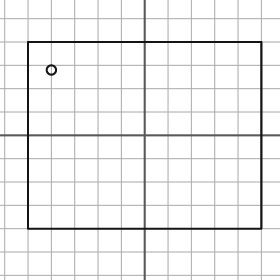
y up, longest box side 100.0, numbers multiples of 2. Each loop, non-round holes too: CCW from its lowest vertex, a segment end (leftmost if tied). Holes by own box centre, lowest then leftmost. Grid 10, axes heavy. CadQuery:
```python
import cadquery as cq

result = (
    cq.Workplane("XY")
    .moveTo(-50.0, -40.0)
    .lineTo(50.0, -40.0)
    .lineTo(50.0, 40.0)
    .lineTo(-50.0, 40.0)
    .close()
    .moveTo(-40.0, 28.0)
    .circle(2.0)
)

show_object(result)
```